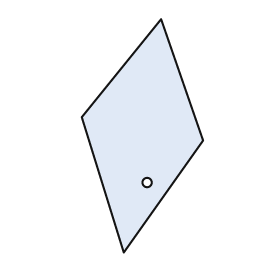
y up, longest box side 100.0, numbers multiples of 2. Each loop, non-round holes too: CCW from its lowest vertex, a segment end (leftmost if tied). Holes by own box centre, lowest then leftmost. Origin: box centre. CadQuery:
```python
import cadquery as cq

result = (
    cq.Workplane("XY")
    .moveTo(-8.0, -50.0)
    .lineTo(26.0, -2.0)
    .lineTo(8.0, 50.0)
    .lineTo(-26.0, 8.0)
    .close()
    .moveTo(2.0, -20.0)
    .circle(2.0)
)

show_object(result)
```